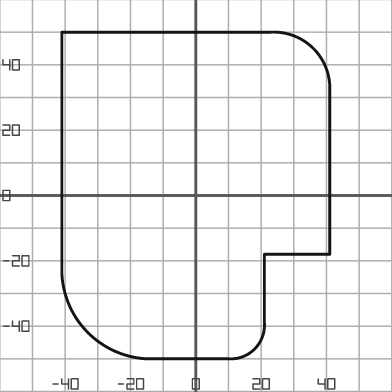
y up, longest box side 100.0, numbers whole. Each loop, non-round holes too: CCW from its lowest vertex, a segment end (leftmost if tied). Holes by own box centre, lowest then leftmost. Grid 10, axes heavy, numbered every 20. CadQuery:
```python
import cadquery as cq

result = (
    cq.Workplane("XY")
    .moveTo(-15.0, -50.0)
    .lineTo(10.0, -50.0)
    .threePointArc((18.0, -47.0), (21.0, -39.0))
    .lineTo(21.0, -18.0)
    .lineTo(41.0, -18.0)
    .lineTo(41.0, 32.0)
    .threePointArc((36.0, 45.0), (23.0, 50.0))
    .lineTo(-41.0, 50.0)
    .lineTo(-41.0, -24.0)
    .threePointArc((-33.0, -42.0), (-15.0, -50.0))
    .close()
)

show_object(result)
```